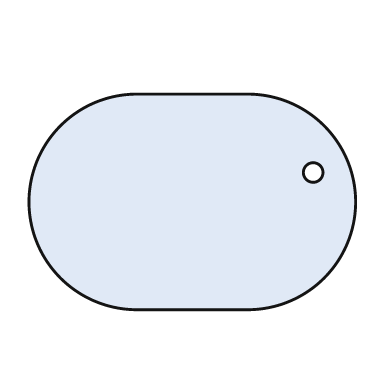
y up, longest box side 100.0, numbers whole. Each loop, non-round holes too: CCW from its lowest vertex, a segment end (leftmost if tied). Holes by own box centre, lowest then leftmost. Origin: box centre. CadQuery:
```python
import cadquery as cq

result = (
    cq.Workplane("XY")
    .moveTo(-17.0, -33.0)
    .lineTo(17.0, -33.0)
    .threePointArc((50.0, 0.0), (17.0, 33.0))
    .lineTo(-17.0, 33.0)
    .threePointArc((-50.0, 0.0), (-17.0, -33.0))
    .close()
    .moveTo(37.0, 9.0)
    .circle(3.0)
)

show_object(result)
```